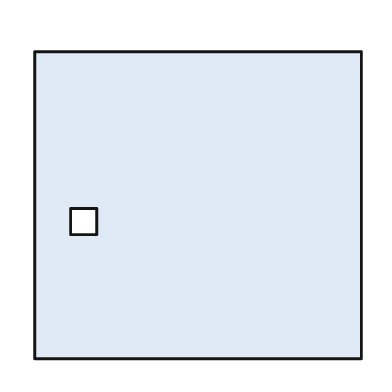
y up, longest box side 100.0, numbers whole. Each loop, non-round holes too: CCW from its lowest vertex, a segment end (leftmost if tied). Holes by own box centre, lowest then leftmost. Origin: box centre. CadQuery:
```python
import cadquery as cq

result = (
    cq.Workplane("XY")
    .moveTo(-50.0, -47.0)
    .lineTo(50.0, -47.0)
    .lineTo(50.0, 47.0)
    .lineTo(-50.0, 47.0)
    .close()
    .moveTo(-39.0, -9.0)
    .lineTo(-31.0, -9.0)
    .lineTo(-31.0, -1.0)
    .lineTo(-39.0, -1.0)
    .close()
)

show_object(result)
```